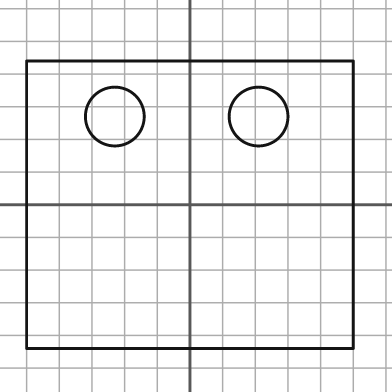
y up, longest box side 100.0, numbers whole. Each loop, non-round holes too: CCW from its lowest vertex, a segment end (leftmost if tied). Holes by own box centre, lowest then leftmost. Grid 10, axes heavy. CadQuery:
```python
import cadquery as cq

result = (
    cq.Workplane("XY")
    .moveTo(-50.0, -44.0)
    .lineTo(50.0, -44.0)
    .lineTo(50.0, 44.0)
    .lineTo(-50.0, 44.0)
    .close()
    .moveTo(-23.0, 27.0)
    .circle(9.0)
    .moveTo(21.0, 27.0)
    .circle(9.0)
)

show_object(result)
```